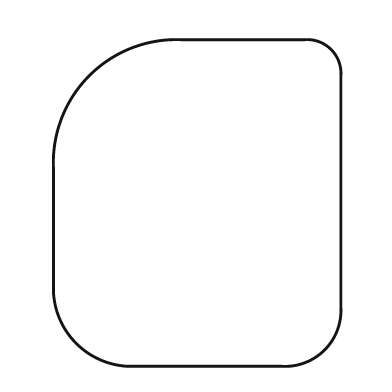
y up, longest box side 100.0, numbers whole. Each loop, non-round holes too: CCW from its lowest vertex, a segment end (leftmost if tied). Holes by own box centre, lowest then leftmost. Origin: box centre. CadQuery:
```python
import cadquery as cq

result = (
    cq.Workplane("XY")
    .moveTo(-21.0, -50.0)
    .lineTo(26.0, -50.0)
    .threePointArc((39.0, -45.0), (44.0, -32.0))
    .lineTo(44.0, 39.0)
    .threePointArc((41.0, 47.0), (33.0, 50.0))
    .lineTo(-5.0, 50.0)
    .threePointArc((-33.0, 39.0), (-44.0, 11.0))
    .lineTo(-44.0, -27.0)
    .threePointArc((-37.0, -43.0), (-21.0, -50.0))
    .close()
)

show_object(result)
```